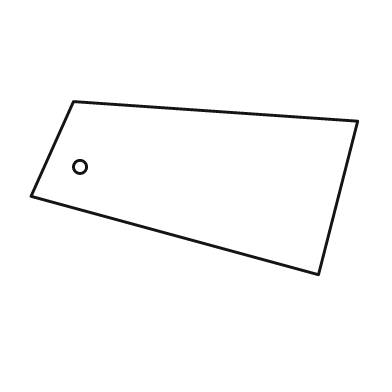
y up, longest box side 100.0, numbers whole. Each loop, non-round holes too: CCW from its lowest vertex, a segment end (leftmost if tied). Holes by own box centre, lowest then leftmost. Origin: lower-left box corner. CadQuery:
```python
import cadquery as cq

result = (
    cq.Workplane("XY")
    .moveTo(88.0, 0.0)
    .lineTo(100.0, 47.0)
    .lineTo(13.0, 53.0)
    .lineTo(0.0, 24.0)
    .close()
    .moveTo(15.0, 33.0)
    .circle(2.0)
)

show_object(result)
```